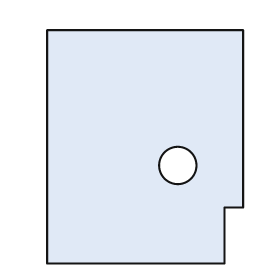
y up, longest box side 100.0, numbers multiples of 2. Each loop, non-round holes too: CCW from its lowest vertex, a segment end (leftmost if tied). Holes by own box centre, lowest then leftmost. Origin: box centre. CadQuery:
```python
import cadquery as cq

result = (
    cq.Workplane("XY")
    .moveTo(-42.0, -50.0)
    .lineTo(34.0, -50.0)
    .lineTo(34.0, -26.0)
    .lineTo(42.0, -26.0)
    .lineTo(42.0, 50.0)
    .lineTo(-42.0, 50.0)
    .close()
    .moveTo(14.0, -8.0)
    .circle(8.0)
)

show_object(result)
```